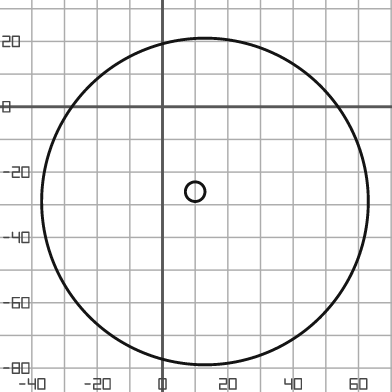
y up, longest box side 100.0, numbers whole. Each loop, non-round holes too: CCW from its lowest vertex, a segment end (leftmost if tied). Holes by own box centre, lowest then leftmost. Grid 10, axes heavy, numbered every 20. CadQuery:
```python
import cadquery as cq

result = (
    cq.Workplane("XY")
    .moveTo(13.0, -29.0)
    .circle(50.0)
    .moveTo(10.0, -26.0)
    .circle(3.0)
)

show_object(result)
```